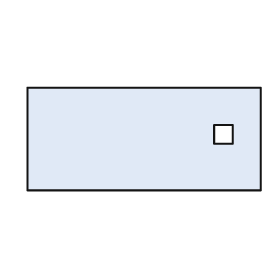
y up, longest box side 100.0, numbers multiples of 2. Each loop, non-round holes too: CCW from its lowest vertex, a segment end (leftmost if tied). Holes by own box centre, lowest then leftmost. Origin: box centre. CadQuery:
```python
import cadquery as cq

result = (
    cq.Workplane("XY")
    .moveTo(-50.0, -22.0)
    .lineTo(50.0, -22.0)
    .lineTo(50.0, 22.0)
    .lineTo(-50.0, 22.0)
    .close()
    .moveTo(30.0, -2.0)
    .lineTo(38.0, -2.0)
    .lineTo(38.0, 6.0)
    .lineTo(30.0, 6.0)
    .close()
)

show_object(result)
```